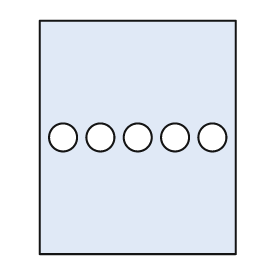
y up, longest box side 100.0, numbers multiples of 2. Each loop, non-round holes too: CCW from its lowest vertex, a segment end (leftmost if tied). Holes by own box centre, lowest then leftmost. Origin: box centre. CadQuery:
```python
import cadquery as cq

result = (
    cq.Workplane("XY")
    .moveTo(-42.0, -50.0)
    .lineTo(42.0, -50.0)
    .lineTo(42.0, 50.0)
    .lineTo(-42.0, 50.0)
    .close()
    .moveTo(-32.0, 0.0)
    .circle(6.0)
    .moveTo(-16.0, 0.0)
    .circle(6.0)
    .moveTo(0.0, 0.0)
    .circle(6.0)
    .moveTo(16.0, 0.0)
    .circle(6.0)
    .moveTo(32.0, 0.0)
    .circle(6.0)
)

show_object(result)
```